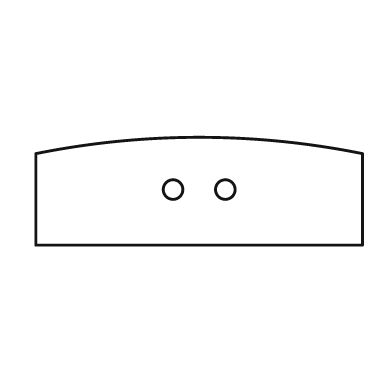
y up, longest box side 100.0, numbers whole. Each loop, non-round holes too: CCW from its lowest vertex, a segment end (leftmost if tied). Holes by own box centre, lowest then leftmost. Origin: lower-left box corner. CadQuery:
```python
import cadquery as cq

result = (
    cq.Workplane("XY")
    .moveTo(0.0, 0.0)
    .lineTo(100.0, 0.0)
    .lineTo(100.0, 28.0)
    .threePointArc((50.0, 33.0), (0.0, 28.0))
    .close()
    .moveTo(42.0, 17.0)
    .circle(3.0)
    .moveTo(58.0, 17.0)
    .circle(3.0)
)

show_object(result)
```